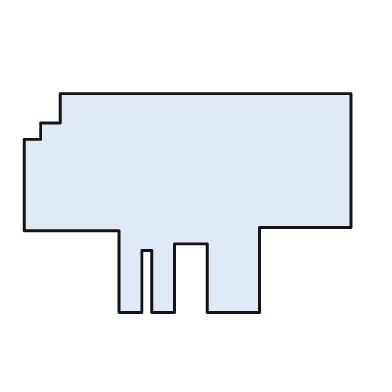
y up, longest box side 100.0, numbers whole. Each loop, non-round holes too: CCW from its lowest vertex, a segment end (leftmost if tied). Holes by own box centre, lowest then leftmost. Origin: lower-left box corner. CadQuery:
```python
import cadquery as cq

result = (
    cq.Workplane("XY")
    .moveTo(29.0, 0.0)
    .lineTo(36.0, 0.0)
    .lineTo(36.0, 19.0)
    .lineTo(39.0, 19.0)
    .lineTo(39.0, 0.0)
    .lineTo(46.0, 0.0)
    .lineTo(46.0, 21.0)
    .lineTo(56.0, 21.0)
    .lineTo(56.0, 0.0)
    .lineTo(72.0, 0.0)
    .lineTo(72.0, 26.0)
    .lineTo(100.0, 26.0)
    .lineTo(100.0, 67.0)
    .lineTo(11.0, 67.0)
    .lineTo(11.0, 58.0)
    .lineTo(5.0, 58.0)
    .lineTo(5.0, 53.0)
    .lineTo(0.0, 53.0)
    .lineTo(0.0, 25.0)
    .lineTo(29.0, 25.0)
    .close()
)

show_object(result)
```